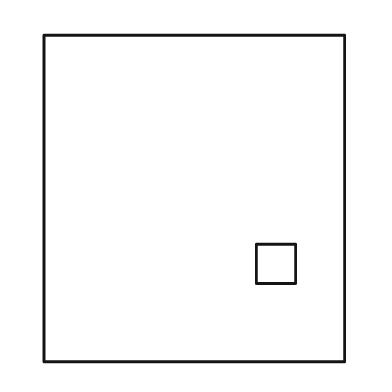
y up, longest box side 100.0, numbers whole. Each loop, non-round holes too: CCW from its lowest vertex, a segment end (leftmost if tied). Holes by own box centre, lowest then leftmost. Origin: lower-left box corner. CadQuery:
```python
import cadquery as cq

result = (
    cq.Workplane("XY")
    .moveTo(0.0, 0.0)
    .lineTo(92.0, 0.0)
    .lineTo(92.0, 100.0)
    .lineTo(0.0, 100.0)
    .close()
    .moveTo(65.0, 24.0)
    .lineTo(77.0, 24.0)
    .lineTo(77.0, 36.0)
    .lineTo(65.0, 36.0)
    .close()
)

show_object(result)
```